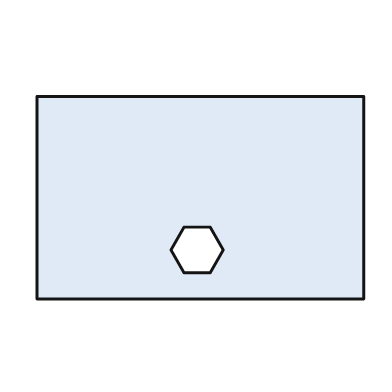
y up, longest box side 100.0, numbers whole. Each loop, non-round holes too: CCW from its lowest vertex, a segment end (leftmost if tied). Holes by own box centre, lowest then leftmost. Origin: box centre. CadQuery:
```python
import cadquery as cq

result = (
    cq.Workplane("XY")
    .moveTo(-50.0, -31.0)
    .lineTo(50.0, -31.0)
    .lineTo(50.0, 31.0)
    .lineTo(-50.0, 31.0)
    .close()
    .moveTo(-5.0, -23.0)
    .lineTo(3.0, -23.0)
    .lineTo(7.0, -16.0)
    .lineTo(3.0, -9.0)
    .lineTo(-5.0, -9.0)
    .lineTo(-9.0, -16.0)
    .close()
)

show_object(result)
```